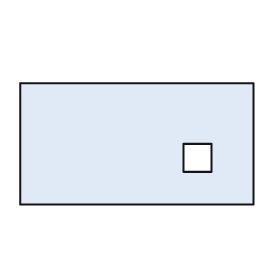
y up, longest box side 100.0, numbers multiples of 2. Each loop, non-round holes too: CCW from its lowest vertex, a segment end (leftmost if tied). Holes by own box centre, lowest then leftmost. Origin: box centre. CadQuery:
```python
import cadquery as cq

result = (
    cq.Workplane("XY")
    .moveTo(-50.0, -26.0)
    .lineTo(50.0, -26.0)
    .lineTo(50.0, 26.0)
    .lineTo(-50.0, 26.0)
    .close()
    .moveTo(20.0, -12.0)
    .lineTo(32.0, -12.0)
    .lineTo(32.0, 0.0)
    .lineTo(20.0, 0.0)
    .close()
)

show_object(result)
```